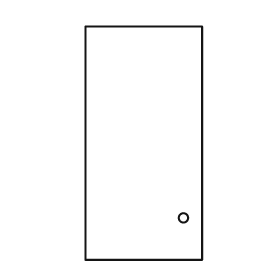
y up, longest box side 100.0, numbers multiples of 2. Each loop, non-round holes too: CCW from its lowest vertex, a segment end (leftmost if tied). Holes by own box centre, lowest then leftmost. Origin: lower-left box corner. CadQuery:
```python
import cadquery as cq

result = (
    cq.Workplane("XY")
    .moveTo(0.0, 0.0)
    .lineTo(50.0, 0.0)
    .lineTo(50.0, 100.0)
    .lineTo(0.0, 100.0)
    .close()
    .moveTo(42.0, 18.0)
    .circle(2.0)
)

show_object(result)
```